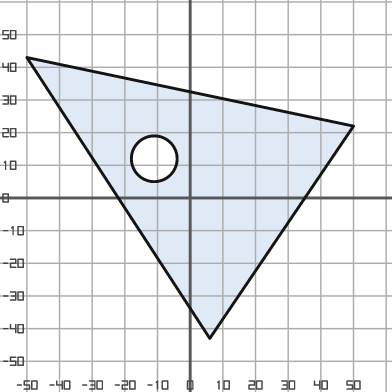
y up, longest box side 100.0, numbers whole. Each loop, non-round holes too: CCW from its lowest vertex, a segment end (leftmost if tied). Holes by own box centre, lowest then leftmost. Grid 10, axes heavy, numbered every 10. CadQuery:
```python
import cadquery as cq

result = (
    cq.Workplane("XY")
    .moveTo(6.0, -43.0)
    .lineTo(50.0, 22.0)
    .lineTo(-50.0, 43.0)
    .close()
    .moveTo(-11.0, 12.0)
    .circle(7.0)
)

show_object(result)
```